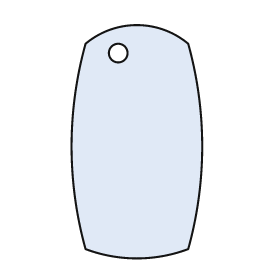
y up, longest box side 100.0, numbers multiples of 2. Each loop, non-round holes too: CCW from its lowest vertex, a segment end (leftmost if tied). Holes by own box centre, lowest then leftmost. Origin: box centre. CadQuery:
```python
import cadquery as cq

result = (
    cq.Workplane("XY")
    .moveTo(-22.0, -46.0)
    .threePointArc((0.0, -50.0), (22.0, -46.0))
    .threePointArc((28.0, -2.0), (22.0, 42.0))
    .threePointArc((0.0, 50.0), (-22.0, 42.0))
    .threePointArc((-28.0, -2.0), (-22.0, -46.0))
    .close()
    .moveTo(-8.0, 38.0)
    .circle(4.0)
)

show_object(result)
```